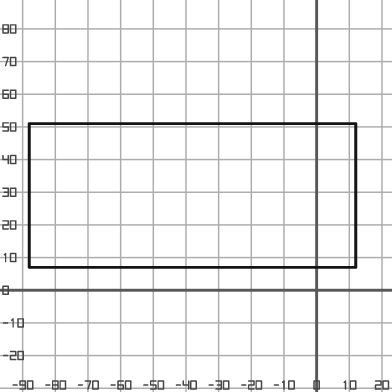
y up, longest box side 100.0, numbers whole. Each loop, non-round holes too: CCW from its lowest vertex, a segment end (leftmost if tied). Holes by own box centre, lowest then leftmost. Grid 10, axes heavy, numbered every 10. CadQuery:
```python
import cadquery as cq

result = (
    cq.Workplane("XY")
    .moveTo(-88.0, 7.0)
    .lineTo(12.0, 7.0)
    .lineTo(12.0, 51.0)
    .lineTo(-88.0, 51.0)
    .close()
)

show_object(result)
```